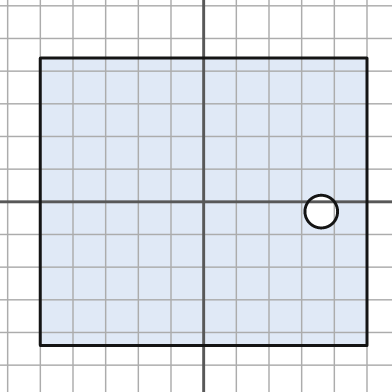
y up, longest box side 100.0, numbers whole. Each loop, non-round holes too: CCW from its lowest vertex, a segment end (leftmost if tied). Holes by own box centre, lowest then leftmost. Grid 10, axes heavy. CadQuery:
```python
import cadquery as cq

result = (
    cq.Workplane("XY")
    .moveTo(-50.0, -44.0)
    .lineTo(50.0, -44.0)
    .lineTo(50.0, 44.0)
    .lineTo(-50.0, 44.0)
    .close()
    .moveTo(36.0, -3.0)
    .circle(5.0)
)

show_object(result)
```